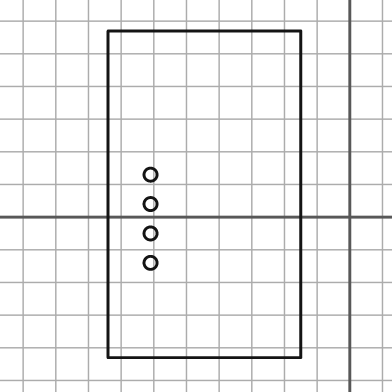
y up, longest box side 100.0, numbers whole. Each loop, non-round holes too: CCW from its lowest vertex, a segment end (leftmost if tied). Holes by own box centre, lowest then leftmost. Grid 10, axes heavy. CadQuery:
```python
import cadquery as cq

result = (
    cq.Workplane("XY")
    .moveTo(-74.0, -43.0)
    .lineTo(-15.0, -43.0)
    .lineTo(-15.0, 57.0)
    .lineTo(-74.0, 57.0)
    .close()
    .moveTo(-61.0, -14.0)
    .circle(2.0)
    .moveTo(-61.0, -5.0)
    .circle(2.0)
    .moveTo(-61.0, 4.0)
    .circle(2.0)
    .moveTo(-61.0, 13.0)
    .circle(2.0)
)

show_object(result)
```